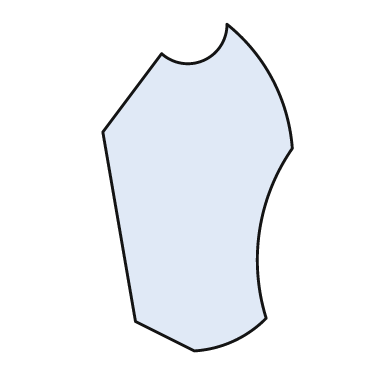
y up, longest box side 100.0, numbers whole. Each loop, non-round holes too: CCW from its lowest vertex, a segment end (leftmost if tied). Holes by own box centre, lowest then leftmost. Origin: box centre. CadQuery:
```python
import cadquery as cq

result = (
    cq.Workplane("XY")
    .moveTo(-1.0, -50.0)
    .threePointArc((11.0, -47.0), (21.0, -40.0))
    .threePointArc((19.0, -13.0), (29.0, 12.0))
    .threePointArc((23.0, 33.0), (9.0, 50.0))
    .threePointArc((2.0, 39.0), (-11.0, 41.0))
    .lineTo(-29.0, 17.0)
    .lineTo(-19.0, -41.0)
    .close()
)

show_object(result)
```